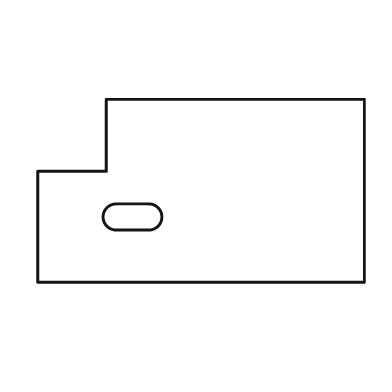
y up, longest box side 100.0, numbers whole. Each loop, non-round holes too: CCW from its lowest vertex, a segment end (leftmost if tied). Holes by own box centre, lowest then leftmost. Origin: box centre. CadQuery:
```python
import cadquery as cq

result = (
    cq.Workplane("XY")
    .moveTo(-50.0, -28.0)
    .lineTo(50.0, -28.0)
    .lineTo(50.0, 28.0)
    .lineTo(-29.0, 28.0)
    .lineTo(-29.0, 6.0)
    .lineTo(-50.0, 6.0)
    .close()
    .moveTo(-26.0, -12.0)
    .lineTo(-16.0, -12.0)
    .threePointArc((-12.0, -8.0), (-16.0, -4.0))
    .lineTo(-26.0, -4.0)
    .threePointArc((-30.0, -8.0), (-26.0, -12.0))
    .close()
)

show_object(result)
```